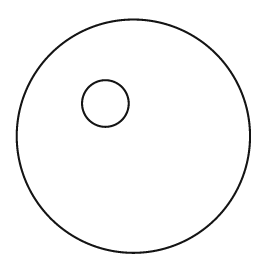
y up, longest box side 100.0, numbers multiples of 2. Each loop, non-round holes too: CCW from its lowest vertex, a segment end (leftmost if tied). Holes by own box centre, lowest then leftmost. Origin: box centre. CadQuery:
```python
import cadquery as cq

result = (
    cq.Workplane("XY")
    .moveTo(0.0, 0.0)
    .circle(50.0)
    .moveTo(-12.0, 14.0)
    .circle(10.0)
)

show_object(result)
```